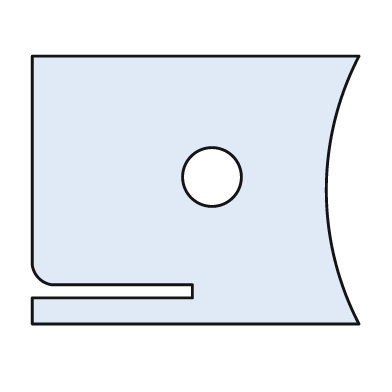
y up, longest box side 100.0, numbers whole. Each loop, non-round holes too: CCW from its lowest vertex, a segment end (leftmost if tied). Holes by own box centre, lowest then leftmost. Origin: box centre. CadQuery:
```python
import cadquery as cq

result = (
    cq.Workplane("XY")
    .moveTo(-50.0, -41.0)
    .lineTo(50.0, -41.0)
    .threePointArc((40.0, 0.0), (50.0, 41.0))
    .lineTo(-50.0, 41.0)
    .lineTo(-50.0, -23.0)
    .threePointArc((-48.0, -27.0), (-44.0, -29.0))
    .lineTo(-1.0, -29.0)
    .lineTo(-1.0, -33.0)
    .lineTo(-50.0, -33.0)
    .close()
    .moveTo(5.0, 4.0)
    .circle(9.0)
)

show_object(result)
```